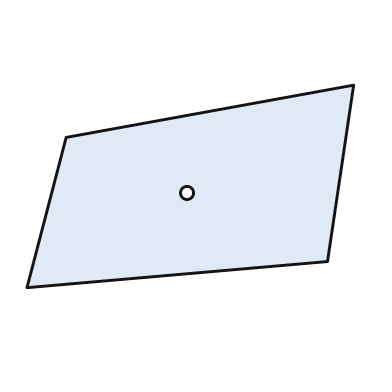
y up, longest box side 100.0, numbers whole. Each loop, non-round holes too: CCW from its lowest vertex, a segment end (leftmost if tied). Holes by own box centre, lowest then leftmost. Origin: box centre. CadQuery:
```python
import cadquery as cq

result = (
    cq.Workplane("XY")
    .moveTo(-50.0, -31.0)
    .lineTo(42.0, -23.0)
    .lineTo(50.0, 31.0)
    .lineTo(-38.0, 15.0)
    .close()
    .moveTo(-1.0, -2.0)
    .circle(2.0)
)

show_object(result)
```